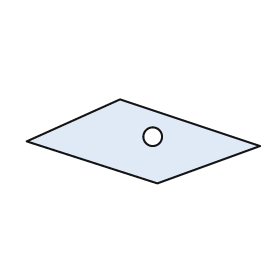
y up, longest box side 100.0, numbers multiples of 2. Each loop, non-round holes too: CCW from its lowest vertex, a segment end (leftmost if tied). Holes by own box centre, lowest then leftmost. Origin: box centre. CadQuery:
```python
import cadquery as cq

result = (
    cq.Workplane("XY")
    .moveTo(6.0, -18.0)
    .lineTo(50.0, -2.0)
    .lineTo(-10.0, 18.0)
    .lineTo(-50.0, 0.0)
    .close()
    .moveTo(4.0, 2.0)
    .circle(4.0)
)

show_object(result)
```